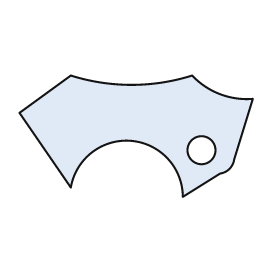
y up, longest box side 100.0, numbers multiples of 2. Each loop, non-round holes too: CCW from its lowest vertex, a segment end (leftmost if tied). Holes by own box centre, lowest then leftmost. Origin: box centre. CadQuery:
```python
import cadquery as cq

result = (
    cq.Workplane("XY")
    .moveTo(20.0, -26.0)
    .lineTo(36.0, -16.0)
    .threePointArc((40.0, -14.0), (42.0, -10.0))
    .lineTo(50.0, 16.0)
    .threePointArc((36.0, 18.0), (24.0, 26.0))
    .threePointArc((-2.0, 22.0), (-28.0, 26.0))
    .lineTo(-50.0, 10.0)
    .lineTo(-28.0, -22.0)
    .threePointArc((-2.0, -2.0), (20.0, -26.0))
    .close()
    .moveTo(28.0, -6.0)
    .circle(6.0)
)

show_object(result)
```